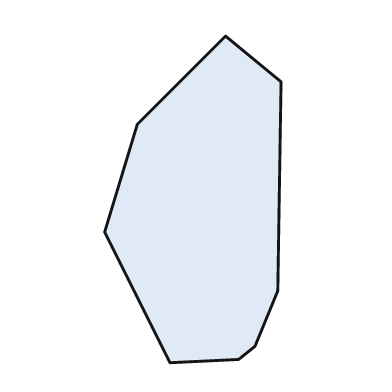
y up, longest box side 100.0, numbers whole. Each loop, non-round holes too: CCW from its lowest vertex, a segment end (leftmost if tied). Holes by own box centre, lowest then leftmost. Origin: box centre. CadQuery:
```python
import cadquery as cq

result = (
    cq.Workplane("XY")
    .moveTo(-7.0, -50.0)
    .lineTo(14.0, -49.0)
    .lineTo(19.0, -45.0)
    .lineTo(26.0, -28.0)
    .lineTo(27.0, 36.0)
    .lineTo(10.0, 50.0)
    .lineTo(-17.0, 23.0)
    .lineTo(-27.0, -10.0)
    .close()
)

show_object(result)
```